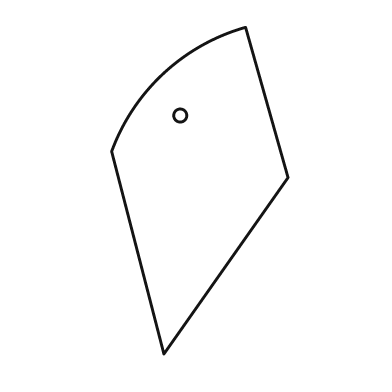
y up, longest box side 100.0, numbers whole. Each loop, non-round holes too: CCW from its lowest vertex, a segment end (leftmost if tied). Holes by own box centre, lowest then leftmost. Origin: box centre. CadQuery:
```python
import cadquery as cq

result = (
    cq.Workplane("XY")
    .moveTo(-11.0, -50.0)
    .lineTo(27.0, 4.0)
    .lineTo(14.0, 50.0)
    .threePointArc((-11.0, 36.0), (-27.0, 12.0))
    .close()
    .moveTo(-6.0, 23.0)
    .circle(2.0)
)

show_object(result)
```